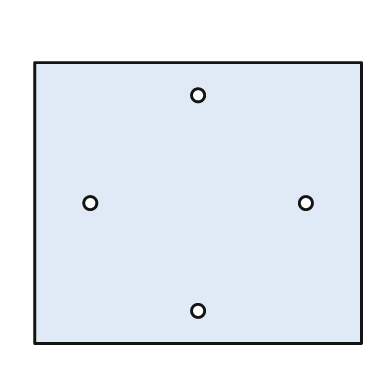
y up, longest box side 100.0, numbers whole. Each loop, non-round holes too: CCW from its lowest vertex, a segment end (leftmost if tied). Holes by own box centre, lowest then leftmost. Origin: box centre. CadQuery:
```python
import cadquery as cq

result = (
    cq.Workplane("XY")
    .moveTo(-50.0, -43.0)
    .lineTo(50.0, -43.0)
    .lineTo(50.0, 43.0)
    .lineTo(-50.0, 43.0)
    .close()
    .moveTo(0.0, -33.0)
    .circle(2.0)
    .moveTo(-33.0, 0.0)
    .circle(2.0)
    .moveTo(33.0, 0.0)
    .circle(2.0)
    .moveTo(0.0, 33.0)
    .circle(2.0)
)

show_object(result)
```